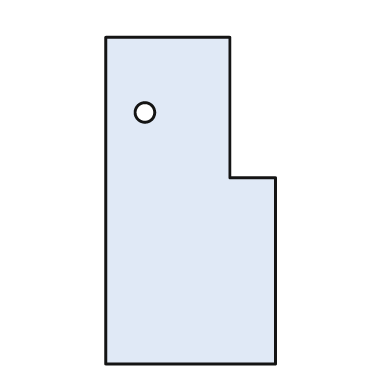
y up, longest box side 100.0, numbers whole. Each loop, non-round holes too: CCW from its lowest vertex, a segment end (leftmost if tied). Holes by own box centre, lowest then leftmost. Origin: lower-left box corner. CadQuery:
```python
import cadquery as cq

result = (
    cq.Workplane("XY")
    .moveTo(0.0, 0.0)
    .lineTo(52.0, 0.0)
    .lineTo(52.0, 57.0)
    .lineTo(38.0, 57.0)
    .lineTo(38.0, 100.0)
    .lineTo(0.0, 100.0)
    .close()
    .moveTo(12.0, 77.0)
    .circle(3.0)
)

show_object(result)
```